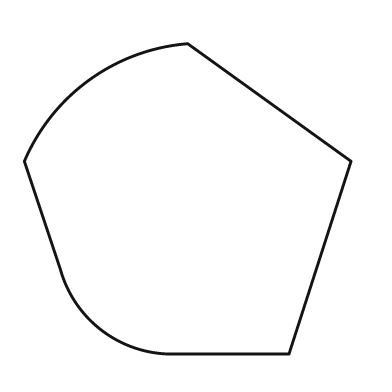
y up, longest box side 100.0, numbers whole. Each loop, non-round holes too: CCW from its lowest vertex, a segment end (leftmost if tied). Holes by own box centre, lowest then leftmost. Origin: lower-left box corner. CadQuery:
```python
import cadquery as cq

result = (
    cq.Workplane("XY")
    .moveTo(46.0, 0.0)
    .lineTo(81.0, 0.0)
    .lineTo(100.0, 59.0)
    .lineTo(50.0, 95.0)
    .threePointArc((20.0, 84.0), (0.0, 59.0))
    .lineTo(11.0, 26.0)
    .threePointArc((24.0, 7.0), (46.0, 0.0))
    .close()
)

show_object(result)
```